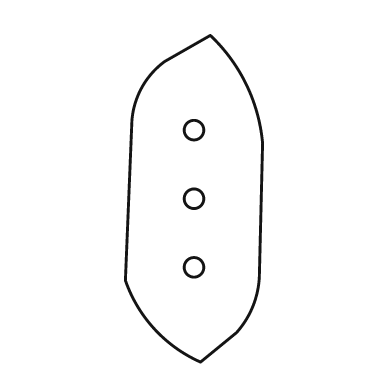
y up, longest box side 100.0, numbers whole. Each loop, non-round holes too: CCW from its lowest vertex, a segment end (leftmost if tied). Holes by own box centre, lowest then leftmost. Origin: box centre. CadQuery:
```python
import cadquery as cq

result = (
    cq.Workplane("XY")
    .moveTo(2.0, -50.0)
    .lineTo(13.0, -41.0)
    .threePointArc((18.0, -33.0), (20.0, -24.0))
    .lineTo(21.0, 17.0)
    .threePointArc((16.0, 35.0), (5.0, 50.0))
    .lineTo(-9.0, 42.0)
    .threePointArc((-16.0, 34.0), (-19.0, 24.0))
    .lineTo(-21.0, -25.0)
    .threePointArc((-12.0, -40.0), (2.0, -50.0))
    .close()
    .moveTo(0.0, -21.0)
    .circle(3.0)
    .moveTo(0.0, 0.0)
    .circle(3.0)
    .moveTo(0.0, 21.0)
    .circle(3.0)
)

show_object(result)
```